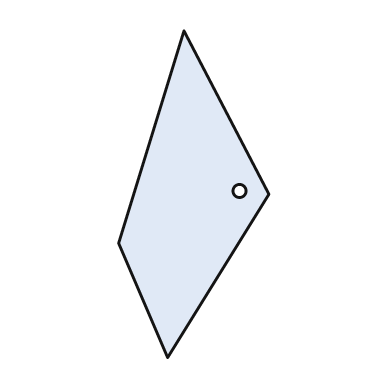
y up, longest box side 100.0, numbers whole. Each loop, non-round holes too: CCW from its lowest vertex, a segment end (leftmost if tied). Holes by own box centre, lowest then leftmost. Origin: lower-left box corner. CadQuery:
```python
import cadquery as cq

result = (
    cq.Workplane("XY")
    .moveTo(15.0, 0.0)
    .lineTo(46.0, 50.0)
    .lineTo(20.0, 100.0)
    .lineTo(0.0, 35.0)
    .close()
    .moveTo(37.0, 51.0)
    .circle(2.0)
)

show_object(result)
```